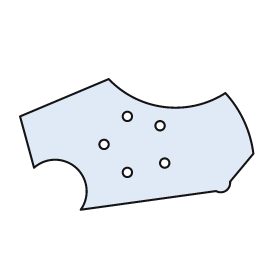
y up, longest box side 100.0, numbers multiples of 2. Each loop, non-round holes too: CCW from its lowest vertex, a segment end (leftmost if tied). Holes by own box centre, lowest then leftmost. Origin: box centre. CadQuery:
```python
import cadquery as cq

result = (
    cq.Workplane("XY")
    .moveTo(-24.0, -28.0)
    .lineTo(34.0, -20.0)
    .threePointArc((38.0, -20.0), (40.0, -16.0))
    .lineTo(50.0, -4.0)
    .threePointArc((46.0, 10.0), (38.0, 22.0))
    .threePointArc((12.0, 16.0), (-12.0, 28.0))
    .lineTo(-50.0, 12.0)
    .lineTo(-44.0, -10.0)
    .threePointArc((-26.0, -10.0), (-24.0, -28.0))
    .close()
    .moveTo(-4.0, -12.0)
    .circle(2.0)
    .moveTo(12.0, -8.0)
    .circle(2.0)
    .moveTo(-14.0, 0.0)
    .circle(2.0)
    .moveTo(10.0, 8.0)
    .circle(2.0)
    .moveTo(-4.0, 12.0)
    .circle(2.0)
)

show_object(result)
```